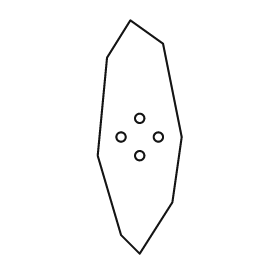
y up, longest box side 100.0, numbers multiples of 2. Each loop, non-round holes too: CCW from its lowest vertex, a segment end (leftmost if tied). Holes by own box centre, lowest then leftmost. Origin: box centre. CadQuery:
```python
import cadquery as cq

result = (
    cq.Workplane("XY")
    .moveTo(0.0, -50.0)
    .lineTo(14.0, -28.0)
    .lineTo(18.0, 0.0)
    .lineTo(10.0, 40.0)
    .lineTo(-4.0, 50.0)
    .lineTo(-14.0, 34.0)
    .lineTo(-18.0, -8.0)
    .lineTo(-8.0, -42.0)
    .close()
    .moveTo(0.0, -8.0)
    .circle(2.0)
    .moveTo(-8.0, 0.0)
    .circle(2.0)
    .moveTo(8.0, 0.0)
    .circle(2.0)
    .moveTo(0.0, 8.0)
    .circle(2.0)
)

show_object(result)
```